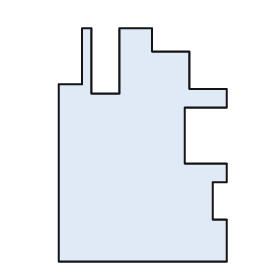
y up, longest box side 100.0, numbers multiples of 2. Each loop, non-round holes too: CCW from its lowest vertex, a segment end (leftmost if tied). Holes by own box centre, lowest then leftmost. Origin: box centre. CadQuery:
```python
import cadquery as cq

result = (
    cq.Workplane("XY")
    .moveTo(-36.0, -50.0)
    .lineTo(36.0, -50.0)
    .lineTo(36.0, -32.0)
    .lineTo(30.0, -32.0)
    .lineTo(30.0, -16.0)
    .lineTo(36.0, -16.0)
    .lineTo(36.0, -8.0)
    .lineTo(18.0, -8.0)
    .lineTo(18.0, 16.0)
    .lineTo(36.0, 16.0)
    .lineTo(36.0, 24.0)
    .lineTo(20.0, 24.0)
    .lineTo(20.0, 40.0)
    .lineTo(4.0, 40.0)
    .lineTo(4.0, 50.0)
    .lineTo(-10.0, 50.0)
    .lineTo(-10.0, 22.0)
    .lineTo(-22.0, 22.0)
    .lineTo(-22.0, 50.0)
    .lineTo(-26.0, 50.0)
    .lineTo(-26.0, 26.0)
    .lineTo(-36.0, 26.0)
    .close()
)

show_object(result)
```